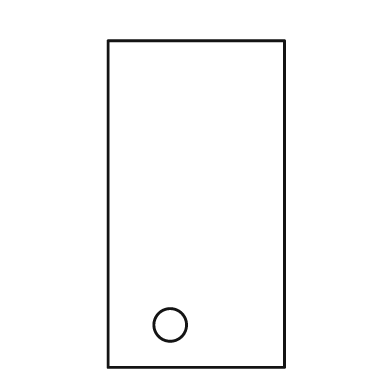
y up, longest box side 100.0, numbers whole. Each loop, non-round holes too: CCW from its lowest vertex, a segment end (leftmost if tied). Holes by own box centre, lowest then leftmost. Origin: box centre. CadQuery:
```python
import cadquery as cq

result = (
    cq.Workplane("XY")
    .moveTo(-27.0, -50.0)
    .lineTo(27.0, -50.0)
    .lineTo(27.0, 50.0)
    .lineTo(-27.0, 50.0)
    .close()
    .moveTo(-8.0, -37.0)
    .circle(5.0)
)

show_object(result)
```